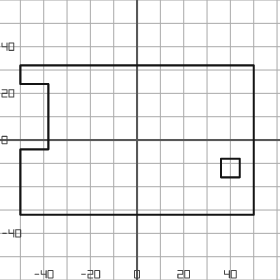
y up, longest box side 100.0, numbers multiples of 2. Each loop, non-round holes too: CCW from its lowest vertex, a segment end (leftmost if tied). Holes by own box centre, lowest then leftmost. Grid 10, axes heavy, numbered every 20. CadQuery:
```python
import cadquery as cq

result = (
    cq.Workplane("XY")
    .moveTo(-50.0, -32.0)
    .lineTo(50.0, -32.0)
    .lineTo(50.0, 32.0)
    .lineTo(-50.0, 32.0)
    .lineTo(-50.0, 24.0)
    .lineTo(-38.0, 24.0)
    .lineTo(-38.0, -4.0)
    .lineTo(-50.0, -4.0)
    .close()
    .moveTo(36.0, -16.0)
    .lineTo(44.0, -16.0)
    .lineTo(44.0, -8.0)
    .lineTo(36.0, -8.0)
    .close()
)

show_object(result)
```